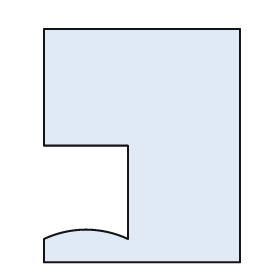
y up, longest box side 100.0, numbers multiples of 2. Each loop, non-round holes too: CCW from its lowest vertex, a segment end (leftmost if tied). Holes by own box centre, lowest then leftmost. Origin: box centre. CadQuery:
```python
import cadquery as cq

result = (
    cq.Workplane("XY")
    .moveTo(-42.0, -50.0)
    .lineTo(42.0, -50.0)
    .lineTo(42.0, 50.0)
    .lineTo(-42.0, 50.0)
    .lineTo(-42.0, 0.0)
    .lineTo(-6.0, 0.0)
    .lineTo(-6.0, -40.0)
    .threePointArc((-24.0, -36.0), (-42.0, -40.0))
    .close()
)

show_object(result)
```